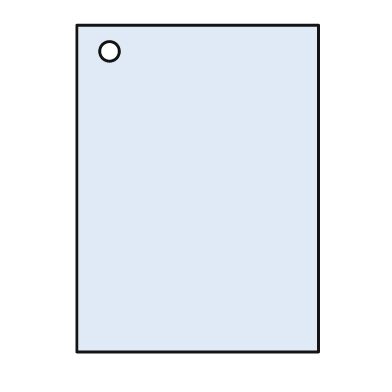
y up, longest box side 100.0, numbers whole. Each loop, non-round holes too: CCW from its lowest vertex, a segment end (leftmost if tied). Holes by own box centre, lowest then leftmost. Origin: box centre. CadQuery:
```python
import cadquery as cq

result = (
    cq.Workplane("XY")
    .moveTo(-37.0, -50.0)
    .lineTo(37.0, -50.0)
    .lineTo(37.0, 50.0)
    .lineTo(-37.0, 50.0)
    .close()
    .moveTo(-27.0, 42.0)
    .circle(3.0)
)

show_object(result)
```